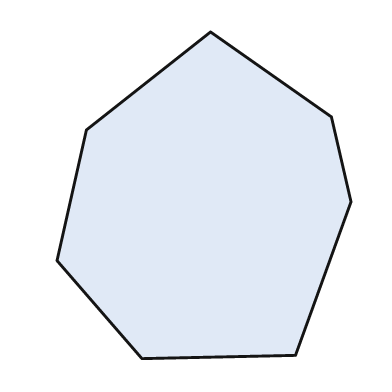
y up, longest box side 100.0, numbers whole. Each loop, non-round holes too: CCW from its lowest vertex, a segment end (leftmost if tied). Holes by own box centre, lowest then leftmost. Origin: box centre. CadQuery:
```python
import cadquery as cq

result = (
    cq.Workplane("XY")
    .moveTo(-19.0, -50.0)
    .lineTo(28.0, -49.0)
    .lineTo(45.0, -2.0)
    .lineTo(39.0, 24.0)
    .lineTo(2.0, 50.0)
    .lineTo(-36.0, 20.0)
    .lineTo(-45.0, -20.0)
    .close()
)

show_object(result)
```